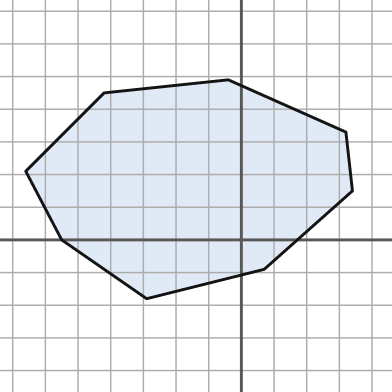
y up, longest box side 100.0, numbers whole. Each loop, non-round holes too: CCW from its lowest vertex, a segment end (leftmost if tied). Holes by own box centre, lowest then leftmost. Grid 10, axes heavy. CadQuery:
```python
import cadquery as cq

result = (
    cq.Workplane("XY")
    .moveTo(-29.0, -18.0)
    .lineTo(7.0, -9.0)
    .lineTo(34.0, 15.0)
    .lineTo(32.0, 33.0)
    .lineTo(-4.0, 49.0)
    .lineTo(-42.0, 45.0)
    .lineTo(-66.0, 21.0)
    .lineTo(-55.0, 0.0)
    .close()
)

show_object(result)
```